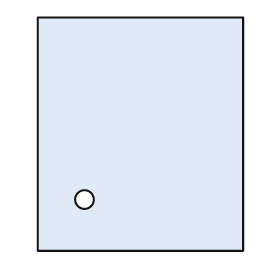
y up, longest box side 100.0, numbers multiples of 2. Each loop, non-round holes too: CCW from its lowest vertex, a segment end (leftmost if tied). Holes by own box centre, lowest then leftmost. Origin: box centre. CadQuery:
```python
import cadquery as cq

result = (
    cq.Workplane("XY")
    .moveTo(-44.0, -50.0)
    .lineTo(44.0, -50.0)
    .lineTo(44.0, 50.0)
    .lineTo(-44.0, 50.0)
    .close()
    .moveTo(-24.0, -28.0)
    .circle(4.0)
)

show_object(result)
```